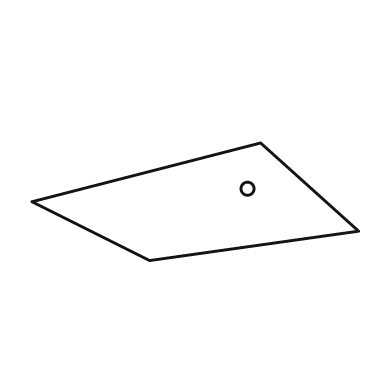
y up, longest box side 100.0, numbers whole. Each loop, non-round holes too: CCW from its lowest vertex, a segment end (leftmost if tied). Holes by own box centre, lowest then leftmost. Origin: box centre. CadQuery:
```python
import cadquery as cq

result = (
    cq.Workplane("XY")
    .moveTo(-14.0, -18.0)
    .lineTo(50.0, -9.0)
    .lineTo(20.0, 18.0)
    .lineTo(-50.0, 0.0)
    .close()
    .moveTo(16.0, 4.0)
    .circle(2.0)
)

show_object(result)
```